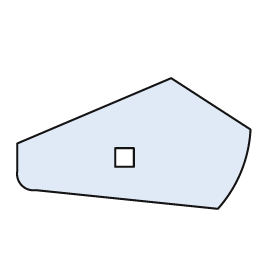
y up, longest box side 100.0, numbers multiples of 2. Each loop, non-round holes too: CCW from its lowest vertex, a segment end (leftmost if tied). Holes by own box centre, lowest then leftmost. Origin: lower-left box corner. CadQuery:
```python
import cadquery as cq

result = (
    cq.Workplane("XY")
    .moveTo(86.0, 0.0)
    .threePointArc((96.0, 16.0), (100.0, 34.0))
    .lineTo(66.0, 56.0)
    .lineTo(0.0, 28.0)
    .lineTo(0.0, 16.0)
    .threePointArc((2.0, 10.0), (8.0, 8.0))
    .close()
    .moveTo(42.0, 18.0)
    .lineTo(50.0, 18.0)
    .lineTo(50.0, 26.0)
    .lineTo(42.0, 26.0)
    .close()
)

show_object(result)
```